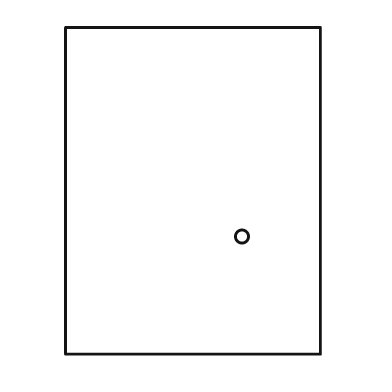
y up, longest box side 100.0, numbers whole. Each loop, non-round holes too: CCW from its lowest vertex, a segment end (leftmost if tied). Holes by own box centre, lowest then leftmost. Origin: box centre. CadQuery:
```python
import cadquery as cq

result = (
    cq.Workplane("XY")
    .moveTo(-39.0, -50.0)
    .lineTo(39.0, -50.0)
    .lineTo(39.0, 50.0)
    .lineTo(-39.0, 50.0)
    .close()
    .moveTo(15.0, -14.0)
    .circle(2.0)
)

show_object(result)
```